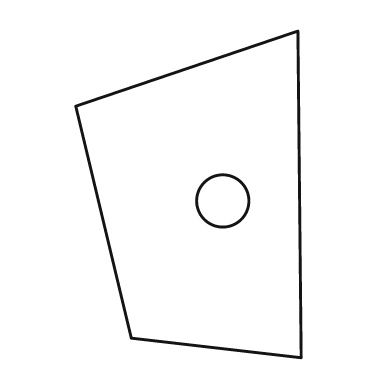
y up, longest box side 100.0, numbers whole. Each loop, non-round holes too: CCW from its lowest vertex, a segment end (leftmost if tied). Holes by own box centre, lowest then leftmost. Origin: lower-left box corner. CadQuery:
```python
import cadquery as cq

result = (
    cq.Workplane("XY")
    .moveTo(69.0, 0.0)
    .lineTo(68.0, 100.0)
    .lineTo(0.0, 77.0)
    .lineTo(17.0, 6.0)
    .close()
    .moveTo(45.0, 48.0)
    .circle(8.0)
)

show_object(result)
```